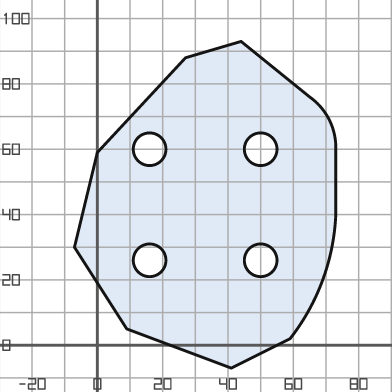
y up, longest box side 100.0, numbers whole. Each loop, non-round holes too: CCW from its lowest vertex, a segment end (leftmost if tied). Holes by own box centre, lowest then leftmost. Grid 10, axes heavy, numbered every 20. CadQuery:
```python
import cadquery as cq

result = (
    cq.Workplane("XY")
    .moveTo(41.0, -7.0)
    .lineTo(59.0, 2.0)
    .threePointArc((69.0, 20.0), (73.0, 40.0))
    .lineTo(73.0, 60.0)
    .threePointArc((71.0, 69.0), (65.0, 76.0))
    .lineTo(44.0, 93.0)
    .lineTo(27.0, 88.0)
    .lineTo(0.0, 59.0)
    .lineTo(-7.0, 30.0)
    .lineTo(9.0, 5.0)
    .close()
    .moveTo(16.0, 26.0)
    .circle(5.0)
    .moveTo(50.0, 26.0)
    .circle(5.0)
    .moveTo(16.0, 60.0)
    .circle(5.0)
    .moveTo(50.0, 60.0)
    .circle(5.0)
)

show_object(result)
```